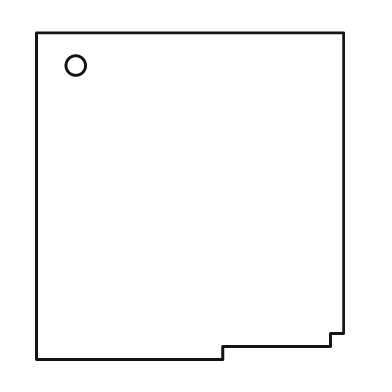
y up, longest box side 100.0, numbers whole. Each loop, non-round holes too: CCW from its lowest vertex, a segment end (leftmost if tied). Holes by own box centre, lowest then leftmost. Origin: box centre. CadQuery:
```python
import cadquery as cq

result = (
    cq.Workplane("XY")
    .moveTo(-47.0, -50.0)
    .lineTo(10.0, -50.0)
    .lineTo(10.0, -46.0)
    .lineTo(43.0, -46.0)
    .lineTo(43.0, -42.0)
    .lineTo(47.0, -42.0)
    .lineTo(47.0, 50.0)
    .lineTo(-47.0, 50.0)
    .close()
    .moveTo(-35.0, 40.0)
    .circle(3.0)
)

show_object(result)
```